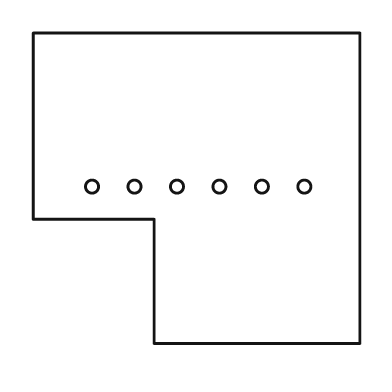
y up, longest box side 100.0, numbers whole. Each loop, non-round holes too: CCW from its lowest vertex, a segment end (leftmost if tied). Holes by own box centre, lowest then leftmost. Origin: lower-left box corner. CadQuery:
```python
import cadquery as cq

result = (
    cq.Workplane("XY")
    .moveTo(37.0, 0.0)
    .lineTo(100.0, 0.0)
    .lineTo(100.0, 95.0)
    .lineTo(0.0, 95.0)
    .lineTo(0.0, 38.0)
    .lineTo(37.0, 38.0)
    .close()
    .moveTo(18.0, 48.0)
    .circle(2.0)
    .moveTo(31.0, 48.0)
    .circle(2.0)
    .moveTo(44.0, 48.0)
    .circle(2.0)
    .moveTo(57.0, 48.0)
    .circle(2.0)
    .moveTo(70.0, 48.0)
    .circle(2.0)
    .moveTo(83.0, 48.0)
    .circle(2.0)
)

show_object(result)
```